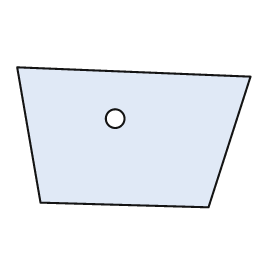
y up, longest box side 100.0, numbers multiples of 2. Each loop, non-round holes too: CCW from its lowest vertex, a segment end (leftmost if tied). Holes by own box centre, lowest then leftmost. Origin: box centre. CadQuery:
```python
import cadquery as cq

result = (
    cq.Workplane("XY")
    .moveTo(32.0, -30.0)
    .lineTo(50.0, 26.0)
    .lineTo(-50.0, 30.0)
    .lineTo(-40.0, -28.0)
    .close()
    .moveTo(-8.0, 8.0)
    .circle(4.0)
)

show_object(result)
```